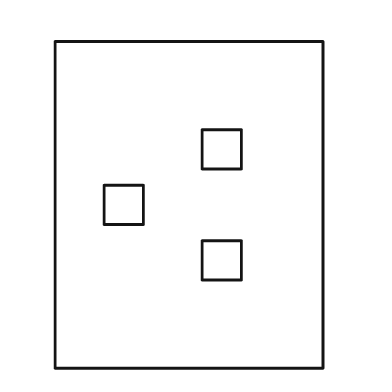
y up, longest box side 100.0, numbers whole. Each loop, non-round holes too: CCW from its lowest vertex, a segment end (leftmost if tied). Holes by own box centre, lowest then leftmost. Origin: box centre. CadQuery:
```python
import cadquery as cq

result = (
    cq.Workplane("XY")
    .moveTo(-41.0, -50.0)
    .lineTo(41.0, -50.0)
    .lineTo(41.0, 50.0)
    .lineTo(-41.0, 50.0)
    .close()
    .moveTo(4.0, -23.0)
    .lineTo(16.0, -23.0)
    .lineTo(16.0, -11.0)
    .lineTo(4.0, -11.0)
    .close()
    .moveTo(-26.0, -6.0)
    .lineTo(-14.0, -6.0)
    .lineTo(-14.0, 6.0)
    .lineTo(-26.0, 6.0)
    .close()
    .moveTo(4.0, 11.0)
    .lineTo(16.0, 11.0)
    .lineTo(16.0, 23.0)
    .lineTo(4.0, 23.0)
    .close()
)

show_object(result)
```